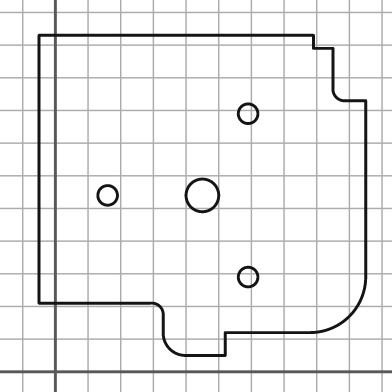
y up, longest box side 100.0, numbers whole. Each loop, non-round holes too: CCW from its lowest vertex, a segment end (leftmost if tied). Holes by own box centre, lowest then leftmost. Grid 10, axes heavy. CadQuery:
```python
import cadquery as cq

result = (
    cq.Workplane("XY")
    .moveTo(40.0, 5.0)
    .lineTo(52.0, 5.0)
    .lineTo(52.0, 12.0)
    .lineTo(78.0, 12.0)
    .threePointArc((90.0, 17.0), (95.0, 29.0))
    .lineTo(95.0, 83.0)
    .lineTo(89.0, 83.0)
    .threePointArc((86.0, 84.0), (85.0, 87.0))
    .lineTo(85.0, 99.0)
    .lineTo(79.0, 99.0)
    .lineTo(79.0, 103.0)
    .lineTo(-5.0, 103.0)
    .lineTo(-5.0, 21.0)
    .lineTo(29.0, 21.0)
    .threePointArc((32.0, 20.0), (33.0, 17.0))
    .lineTo(33.0, 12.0)
    .threePointArc((35.0, 7.0), (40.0, 5.0))
    .close()
    .moveTo(59.0, 29.0)
    .circle(3.0)
    .moveTo(16.0, 54.0)
    .circle(3.0)
    .moveTo(45.0, 54.0)
    .circle(5.0)
    .moveTo(59.0, 79.0)
    .circle(3.0)
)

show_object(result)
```